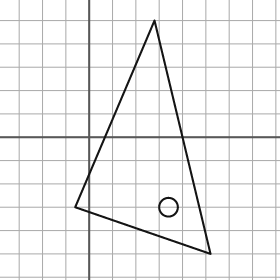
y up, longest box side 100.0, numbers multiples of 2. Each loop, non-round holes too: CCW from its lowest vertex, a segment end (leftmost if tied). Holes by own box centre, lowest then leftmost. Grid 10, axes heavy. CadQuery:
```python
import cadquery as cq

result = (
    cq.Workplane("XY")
    .moveTo(52.0, -50.0)
    .lineTo(28.0, 50.0)
    .lineTo(-6.0, -30.0)
    .close()
    .moveTo(34.0, -30.0)
    .circle(4.0)
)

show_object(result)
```